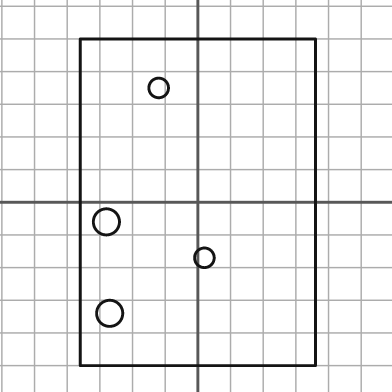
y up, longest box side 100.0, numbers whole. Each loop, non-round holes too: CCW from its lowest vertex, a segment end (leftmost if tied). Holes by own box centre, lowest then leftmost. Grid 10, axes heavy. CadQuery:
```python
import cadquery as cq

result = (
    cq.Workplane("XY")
    .moveTo(-36.0, -50.0)
    .lineTo(36.0, -50.0)
    .lineTo(36.0, 50.0)
    .lineTo(-36.0, 50.0)
    .close()
    .moveTo(-27.0, -34.0)
    .circle(4.0)
    .moveTo(2.0, -17.0)
    .circle(3.0)
    .moveTo(-28.0, -6.0)
    .circle(4.0)
    .moveTo(-12.0, 35.0)
    .circle(3.0)
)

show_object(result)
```